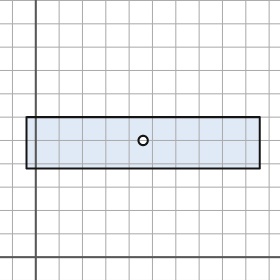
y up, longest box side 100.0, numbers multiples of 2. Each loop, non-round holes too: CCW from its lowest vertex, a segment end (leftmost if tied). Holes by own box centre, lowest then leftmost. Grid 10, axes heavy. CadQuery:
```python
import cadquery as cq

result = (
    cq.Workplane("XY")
    .moveTo(-4.0, 38.0)
    .lineTo(96.0, 38.0)
    .lineTo(96.0, 60.0)
    .lineTo(-4.0, 60.0)
    .close()
    .moveTo(46.0, 50.0)
    .circle(2.0)
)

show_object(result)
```